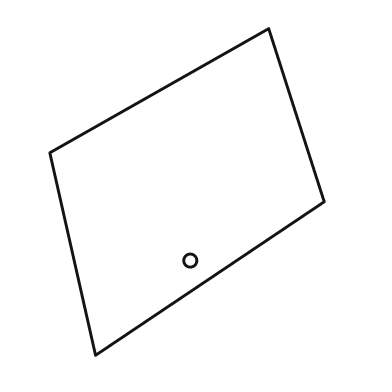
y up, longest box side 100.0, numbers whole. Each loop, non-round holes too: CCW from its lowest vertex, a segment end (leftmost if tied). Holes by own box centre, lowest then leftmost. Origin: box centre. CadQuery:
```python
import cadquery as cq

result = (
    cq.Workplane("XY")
    .moveTo(-28.0, -50.0)
    .lineTo(42.0, -3.0)
    .lineTo(25.0, 50.0)
    .lineTo(-42.0, 12.0)
    .close()
    .moveTo(1.0, -21.0)
    .circle(2.0)
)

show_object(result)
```